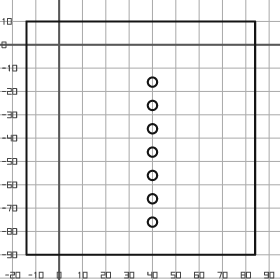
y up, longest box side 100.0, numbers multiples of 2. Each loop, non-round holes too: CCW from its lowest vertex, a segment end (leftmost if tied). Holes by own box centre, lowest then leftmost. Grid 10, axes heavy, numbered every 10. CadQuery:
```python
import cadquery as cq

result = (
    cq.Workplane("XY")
    .moveTo(-14.0, -90.0)
    .lineTo(84.0, -90.0)
    .lineTo(84.0, 10.0)
    .lineTo(-14.0, 10.0)
    .close()
    .moveTo(40.0, -76.0)
    .circle(2.0)
    .moveTo(40.0, -66.0)
    .circle(2.0)
    .moveTo(40.0, -56.0)
    .circle(2.0)
    .moveTo(40.0, -46.0)
    .circle(2.0)
    .moveTo(40.0, -36.0)
    .circle(2.0)
    .moveTo(40.0, -26.0)
    .circle(2.0)
    .moveTo(40.0, -16.0)
    .circle(2.0)
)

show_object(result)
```